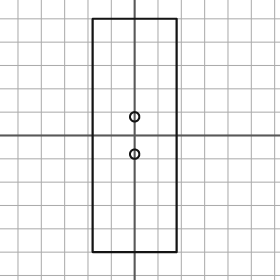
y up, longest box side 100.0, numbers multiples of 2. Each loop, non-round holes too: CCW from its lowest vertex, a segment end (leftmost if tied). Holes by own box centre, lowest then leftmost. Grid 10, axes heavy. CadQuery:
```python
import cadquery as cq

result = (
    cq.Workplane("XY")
    .moveTo(-18.0, -50.0)
    .lineTo(18.0, -50.0)
    .lineTo(18.0, 50.0)
    .lineTo(-18.0, 50.0)
    .close()
    .moveTo(0.0, -8.0)
    .circle(2.0)
    .moveTo(0.0, 8.0)
    .circle(2.0)
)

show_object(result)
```